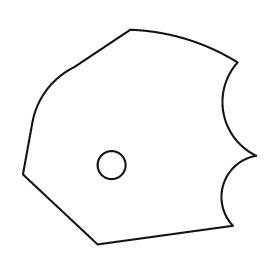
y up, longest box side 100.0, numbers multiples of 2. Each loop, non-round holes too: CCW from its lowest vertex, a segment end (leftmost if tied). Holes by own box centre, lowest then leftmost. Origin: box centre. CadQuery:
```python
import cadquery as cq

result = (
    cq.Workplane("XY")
    .moveTo(-18.0, -46.0)
    .lineTo(40.0, -38.0)
    .threePointArc((36.0, -20.0), (50.0, -8.0))
    .threePointArc((36.0, 10.0), (42.0, 32.0))
    .threePointArc((20.0, 42.0), (-4.0, 46.0))
    .lineTo(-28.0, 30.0)
    .threePointArc((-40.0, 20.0), (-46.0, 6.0))
    .lineTo(-50.0, -16.0)
    .close()
    .moveTo(-12.0, -12.0)
    .circle(6.0)
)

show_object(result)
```